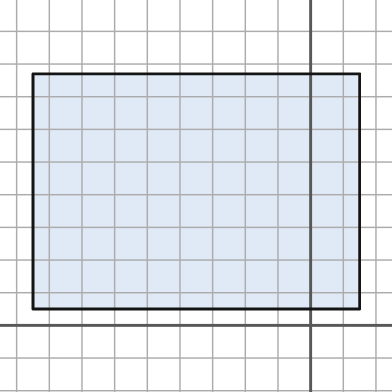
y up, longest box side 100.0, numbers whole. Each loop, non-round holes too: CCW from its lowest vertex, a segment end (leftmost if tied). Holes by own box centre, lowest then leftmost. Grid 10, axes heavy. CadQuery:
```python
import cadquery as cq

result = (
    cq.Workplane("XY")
    .moveTo(-85.0, 5.0)
    .lineTo(15.0, 5.0)
    .lineTo(15.0, 77.0)
    .lineTo(-85.0, 77.0)
    .close()
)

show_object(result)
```